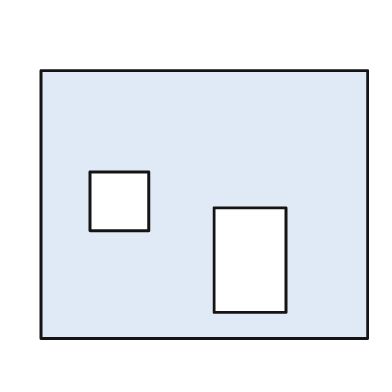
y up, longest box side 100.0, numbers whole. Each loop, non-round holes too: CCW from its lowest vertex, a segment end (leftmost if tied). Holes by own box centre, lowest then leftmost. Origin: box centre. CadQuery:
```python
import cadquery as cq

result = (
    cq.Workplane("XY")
    .moveTo(-50.0, -41.0)
    .lineTo(50.0, -41.0)
    .lineTo(50.0, 41.0)
    .lineTo(-50.0, 41.0)
    .close()
    .moveTo(3.0, -33.0)
    .lineTo(25.0, -33.0)
    .lineTo(25.0, -1.0)
    .lineTo(3.0, -1.0)
    .close()
    .moveTo(-35.0, -8.0)
    .lineTo(-17.0, -8.0)
    .lineTo(-17.0, 10.0)
    .lineTo(-35.0, 10.0)
    .close()
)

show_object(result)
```